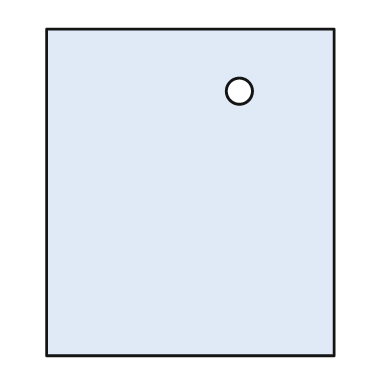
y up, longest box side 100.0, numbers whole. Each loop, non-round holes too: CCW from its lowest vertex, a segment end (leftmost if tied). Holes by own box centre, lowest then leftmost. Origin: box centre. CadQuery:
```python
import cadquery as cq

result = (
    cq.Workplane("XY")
    .moveTo(-44.0, -50.0)
    .lineTo(44.0, -50.0)
    .lineTo(44.0, 50.0)
    .lineTo(-44.0, 50.0)
    .close()
    .moveTo(15.0, 31.0)
    .circle(4.0)
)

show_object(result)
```